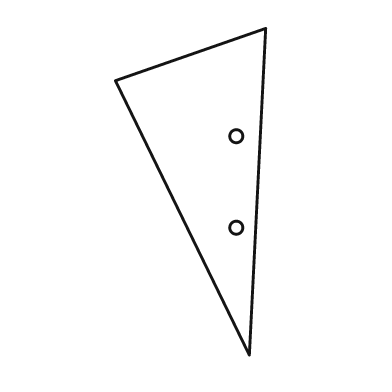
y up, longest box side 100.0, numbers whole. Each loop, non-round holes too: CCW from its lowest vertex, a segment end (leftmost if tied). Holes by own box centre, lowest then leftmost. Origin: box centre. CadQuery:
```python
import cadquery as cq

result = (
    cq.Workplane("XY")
    .moveTo(18.0, -50.0)
    .lineTo(23.0, 50.0)
    .lineTo(-23.0, 34.0)
    .close()
    .moveTo(14.0, -11.0)
    .circle(2.0)
    .moveTo(14.0, 17.0)
    .circle(2.0)
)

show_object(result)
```